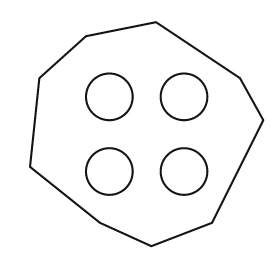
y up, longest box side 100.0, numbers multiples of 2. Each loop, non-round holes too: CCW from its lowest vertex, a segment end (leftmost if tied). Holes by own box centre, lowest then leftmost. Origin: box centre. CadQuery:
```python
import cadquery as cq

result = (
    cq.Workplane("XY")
    .moveTo(2.0, -48.0)
    .lineTo(28.0, -38.0)
    .lineTo(50.0, 6.0)
    .lineTo(40.0, 24.0)
    .lineTo(4.0, 48.0)
    .lineTo(-26.0, 42.0)
    .lineTo(-46.0, 24.0)
    .lineTo(-50.0, -14.0)
    .lineTo(-20.0, -38.0)
    .close()
    .moveTo(-16.0, -16.0)
    .circle(10.0)
    .moveTo(16.0, -16.0)
    .circle(10.0)
    .moveTo(-16.0, 16.0)
    .circle(10.0)
    .moveTo(16.0, 16.0)
    .circle(10.0)
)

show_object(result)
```